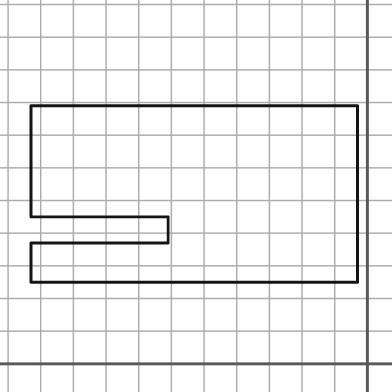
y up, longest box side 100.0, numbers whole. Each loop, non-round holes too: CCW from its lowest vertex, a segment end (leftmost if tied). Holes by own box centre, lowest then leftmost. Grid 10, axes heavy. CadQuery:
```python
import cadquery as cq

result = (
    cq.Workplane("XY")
    .moveTo(-103.0, 25.0)
    .lineTo(-3.0, 25.0)
    .lineTo(-3.0, 79.0)
    .lineTo(-103.0, 79.0)
    .lineTo(-103.0, 45.0)
    .lineTo(-61.0, 45.0)
    .lineTo(-61.0, 37.0)
    .lineTo(-103.0, 37.0)
    .close()
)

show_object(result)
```